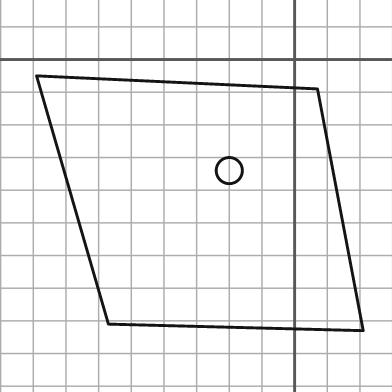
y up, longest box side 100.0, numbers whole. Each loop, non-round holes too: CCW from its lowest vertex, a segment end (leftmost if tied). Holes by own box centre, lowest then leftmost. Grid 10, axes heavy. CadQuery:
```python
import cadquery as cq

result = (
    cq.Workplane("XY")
    .moveTo(21.0, -83.0)
    .lineTo(7.0, -9.0)
    .lineTo(-79.0, -5.0)
    .lineTo(-57.0, -81.0)
    .close()
    .moveTo(-20.0, -34.0)
    .circle(4.0)
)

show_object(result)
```